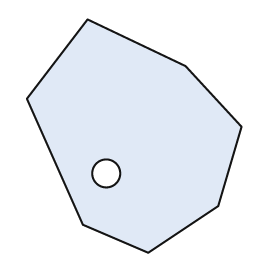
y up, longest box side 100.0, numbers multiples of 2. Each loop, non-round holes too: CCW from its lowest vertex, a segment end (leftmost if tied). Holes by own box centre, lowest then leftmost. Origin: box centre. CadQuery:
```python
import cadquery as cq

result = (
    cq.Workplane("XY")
    .moveTo(6.0, -50.0)
    .lineTo(36.0, -30.0)
    .lineTo(46.0, 4.0)
    .lineTo(22.0, 30.0)
    .lineTo(-20.0, 50.0)
    .lineTo(-46.0, 16.0)
    .lineTo(-22.0, -38.0)
    .close()
    .moveTo(-12.0, -16.0)
    .circle(6.0)
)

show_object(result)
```